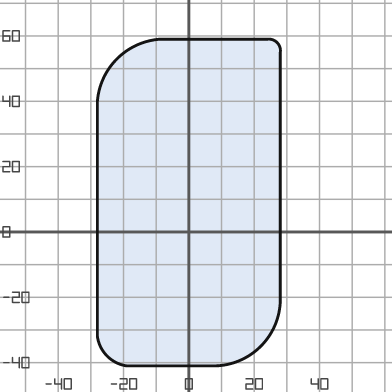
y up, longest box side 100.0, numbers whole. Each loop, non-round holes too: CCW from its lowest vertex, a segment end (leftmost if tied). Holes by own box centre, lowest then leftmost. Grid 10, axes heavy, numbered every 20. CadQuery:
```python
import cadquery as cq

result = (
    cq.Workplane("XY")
    .moveTo(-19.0, -41.0)
    .lineTo(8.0, -41.0)
    .threePointArc((22.0, -35.0), (28.0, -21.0))
    .lineTo(28.0, 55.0)
    .threePointArc((27.0, 58.0), (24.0, 59.0))
    .lineTo(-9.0, 59.0)
    .threePointArc((-22.0, 53.0), (-28.0, 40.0))
    .lineTo(-28.0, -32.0)
    .threePointArc((-25.0, -38.0), (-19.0, -41.0))
    .close()
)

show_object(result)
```